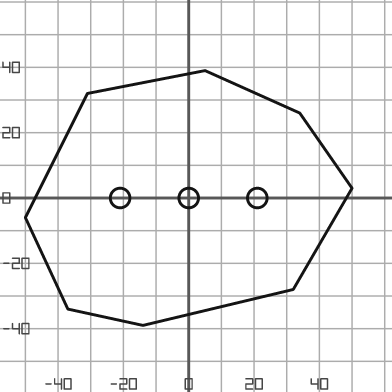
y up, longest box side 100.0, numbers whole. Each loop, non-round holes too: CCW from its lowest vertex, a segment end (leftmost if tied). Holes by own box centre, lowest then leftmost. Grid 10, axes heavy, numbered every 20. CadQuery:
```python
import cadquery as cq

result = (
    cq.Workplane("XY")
    .moveTo(-14.0, -39.0)
    .lineTo(32.0, -28.0)
    .lineTo(50.0, 3.0)
    .lineTo(34.0, 26.0)
    .lineTo(5.0, 39.0)
    .lineTo(-31.0, 32.0)
    .lineTo(-50.0, -6.0)
    .lineTo(-37.0, -34.0)
    .close()
    .moveTo(-21.0, 0.0)
    .circle(3.0)
    .moveTo(0.0, 0.0)
    .circle(3.0)
    .moveTo(21.0, 0.0)
    .circle(3.0)
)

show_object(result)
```